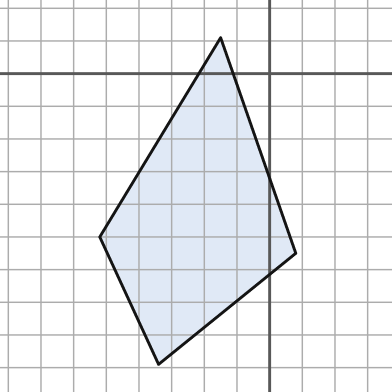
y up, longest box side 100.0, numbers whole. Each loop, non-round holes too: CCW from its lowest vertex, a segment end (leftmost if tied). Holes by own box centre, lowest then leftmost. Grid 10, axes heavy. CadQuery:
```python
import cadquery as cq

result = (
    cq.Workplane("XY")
    .moveTo(-34.0, -89.0)
    .lineTo(8.0, -55.0)
    .lineTo(-15.0, 11.0)
    .lineTo(-52.0, -50.0)
    .close()
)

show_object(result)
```